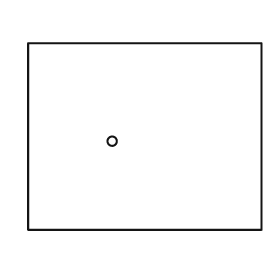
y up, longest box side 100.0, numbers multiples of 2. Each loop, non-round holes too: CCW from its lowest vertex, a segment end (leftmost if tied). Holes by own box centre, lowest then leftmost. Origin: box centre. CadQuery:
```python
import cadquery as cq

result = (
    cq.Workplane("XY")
    .moveTo(-50.0, -40.0)
    .lineTo(50.0, -40.0)
    .lineTo(50.0, 40.0)
    .lineTo(-50.0, 40.0)
    .close()
    .moveTo(-14.0, -2.0)
    .circle(2.0)
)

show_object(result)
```